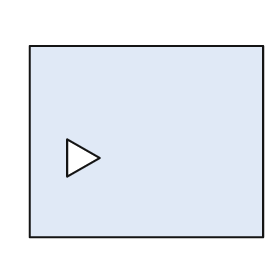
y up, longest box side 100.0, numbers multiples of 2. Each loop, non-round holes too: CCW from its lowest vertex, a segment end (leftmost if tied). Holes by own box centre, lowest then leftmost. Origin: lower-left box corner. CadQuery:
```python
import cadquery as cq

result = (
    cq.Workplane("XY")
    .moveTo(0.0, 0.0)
    .lineTo(100.0, 0.0)
    .lineTo(100.0, 82.0)
    .lineTo(0.0, 82.0)
    .close()
    .moveTo(16.0, 26.0)
    .lineTo(30.0, 34.0)
    .lineTo(16.0, 42.0)
    .close()
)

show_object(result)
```